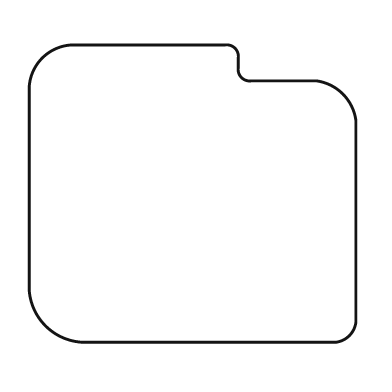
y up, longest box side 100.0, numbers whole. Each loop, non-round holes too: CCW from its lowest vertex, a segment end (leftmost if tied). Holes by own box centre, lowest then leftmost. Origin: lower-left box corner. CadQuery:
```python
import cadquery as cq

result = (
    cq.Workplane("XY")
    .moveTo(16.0, 0.0)
    .lineTo(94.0, 0.0)
    .threePointArc((98.0, 2.0), (100.0, 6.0))
    .lineTo(100.0, 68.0)
    .threePointArc((96.0, 76.0), (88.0, 80.0))
    .lineTo(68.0, 80.0)
    .threePointArc((65.0, 81.0), (64.0, 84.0))
    .lineTo(64.0, 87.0)
    .threePointArc((63.0, 90.0), (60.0, 91.0))
    .lineTo(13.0, 91.0)
    .threePointArc((4.0, 87.0), (0.0, 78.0))
    .lineTo(0.0, 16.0)
    .threePointArc((5.0, 5.0), (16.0, 0.0))
    .close()
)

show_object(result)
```